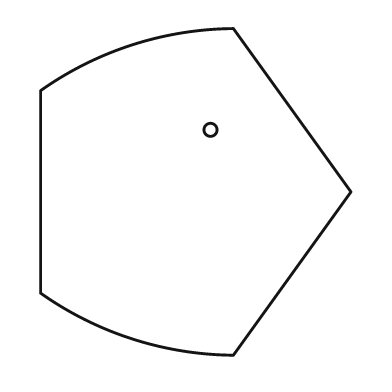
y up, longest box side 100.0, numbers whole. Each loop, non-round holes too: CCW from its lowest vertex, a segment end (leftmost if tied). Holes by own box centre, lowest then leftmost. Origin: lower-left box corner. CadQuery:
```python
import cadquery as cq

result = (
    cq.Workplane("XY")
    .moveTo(59.0, 0.0)
    .lineTo(95.0, 50.0)
    .lineTo(59.0, 100.0)
    .threePointArc((28.0, 95.0), (0.0, 81.0))
    .lineTo(0.0, 19.0)
    .threePointArc((28.0, 5.0), (59.0, 0.0))
    .close()
    .moveTo(52.0, 69.0)
    .circle(2.0)
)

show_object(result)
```